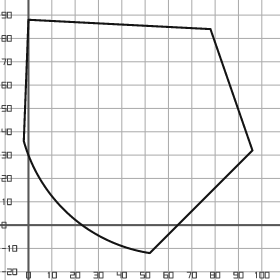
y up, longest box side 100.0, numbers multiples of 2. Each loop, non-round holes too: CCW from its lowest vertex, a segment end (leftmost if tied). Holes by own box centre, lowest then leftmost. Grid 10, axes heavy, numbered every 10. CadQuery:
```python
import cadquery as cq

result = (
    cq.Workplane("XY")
    .moveTo(52.0, -12.0)
    .lineTo(96.0, 32.0)
    .lineTo(78.0, 84.0)
    .lineTo(0.0, 88.0)
    .lineTo(-2.0, 36.0)
    .threePointArc((18.0, 4.0), (52.0, -12.0))
    .close()
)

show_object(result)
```